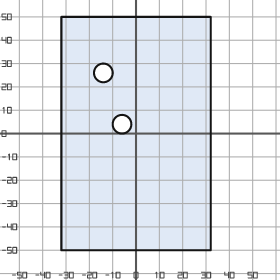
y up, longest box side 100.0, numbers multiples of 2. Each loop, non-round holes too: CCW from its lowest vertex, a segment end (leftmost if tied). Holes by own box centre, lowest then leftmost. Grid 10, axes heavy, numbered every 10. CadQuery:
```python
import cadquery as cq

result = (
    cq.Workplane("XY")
    .moveTo(-32.0, -50.0)
    .lineTo(32.0, -50.0)
    .lineTo(32.0, 50.0)
    .lineTo(-32.0, 50.0)
    .close()
    .moveTo(-6.0, 4.0)
    .circle(4.0)
    .moveTo(-14.0, 26.0)
    .circle(4.0)
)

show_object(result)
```